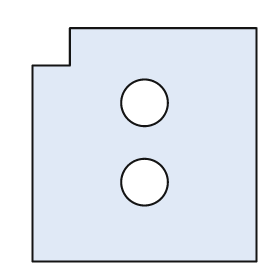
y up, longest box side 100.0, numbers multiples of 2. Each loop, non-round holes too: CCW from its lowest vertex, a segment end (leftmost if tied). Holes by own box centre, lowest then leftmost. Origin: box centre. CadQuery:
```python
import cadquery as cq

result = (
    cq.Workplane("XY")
    .moveTo(-48.0, -50.0)
    .lineTo(48.0, -50.0)
    .lineTo(48.0, 50.0)
    .lineTo(-32.0, 50.0)
    .lineTo(-32.0, 34.0)
    .lineTo(-48.0, 34.0)
    .close()
    .moveTo(0.0, -16.0)
    .circle(10.0)
    .moveTo(0.0, 18.0)
    .circle(10.0)
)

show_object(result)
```